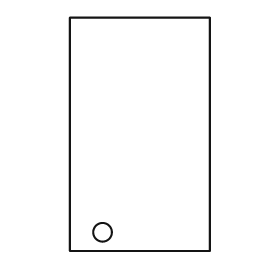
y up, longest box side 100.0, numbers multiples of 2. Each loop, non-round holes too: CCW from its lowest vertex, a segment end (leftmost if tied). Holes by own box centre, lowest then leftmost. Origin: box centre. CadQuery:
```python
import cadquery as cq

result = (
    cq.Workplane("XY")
    .moveTo(-30.0, -50.0)
    .lineTo(30.0, -50.0)
    .lineTo(30.0, 50.0)
    .lineTo(-30.0, 50.0)
    .close()
    .moveTo(-16.0, -42.0)
    .circle(4.0)
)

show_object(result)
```